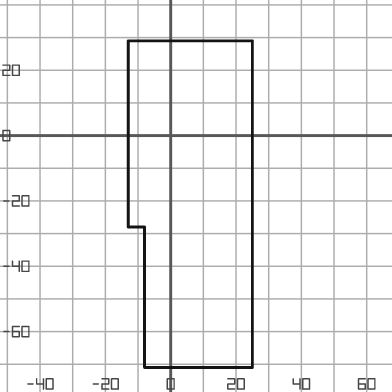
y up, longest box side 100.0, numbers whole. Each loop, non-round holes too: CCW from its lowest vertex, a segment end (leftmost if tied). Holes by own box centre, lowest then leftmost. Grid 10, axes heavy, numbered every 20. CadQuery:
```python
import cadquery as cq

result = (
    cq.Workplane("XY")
    .moveTo(-8.0, -71.0)
    .lineTo(25.0, -71.0)
    .lineTo(25.0, 29.0)
    .lineTo(-13.0, 29.0)
    .lineTo(-13.0, -28.0)
    .lineTo(-8.0, -28.0)
    .close()
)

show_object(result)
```